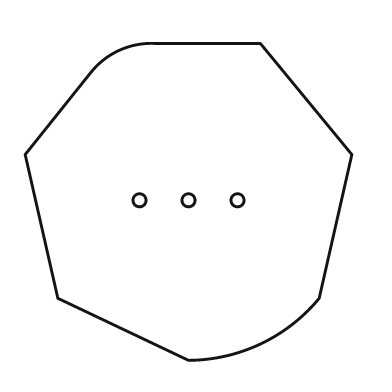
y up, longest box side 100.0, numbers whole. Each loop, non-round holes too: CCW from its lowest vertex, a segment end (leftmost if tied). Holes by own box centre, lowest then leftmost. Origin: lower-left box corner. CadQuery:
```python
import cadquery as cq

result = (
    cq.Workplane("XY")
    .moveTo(50.0, 0.0)
    .threePointArc((72.0, 5.0), (90.0, 19.0))
    .lineTo(100.0, 63.0)
    .lineTo(72.0, 97.0)
    .lineTo(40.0, 97.0)
    .threePointArc((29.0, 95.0), (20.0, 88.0))
    .lineTo(0.0, 63.0)
    .lineTo(10.0, 19.0)
    .close()
    .moveTo(35.0, 49.0)
    .circle(2.0)
    .moveTo(50.0, 49.0)
    .circle(2.0)
    .moveTo(65.0, 49.0)
    .circle(2.0)
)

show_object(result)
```